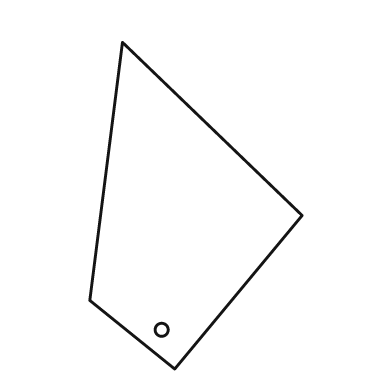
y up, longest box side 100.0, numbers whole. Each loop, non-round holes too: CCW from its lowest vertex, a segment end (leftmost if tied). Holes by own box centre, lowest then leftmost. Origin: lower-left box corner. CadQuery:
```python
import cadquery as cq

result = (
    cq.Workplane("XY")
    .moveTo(26.0, 0.0)
    .lineTo(65.0, 47.0)
    .lineTo(10.0, 100.0)
    .lineTo(0.0, 21.0)
    .close()
    .moveTo(22.0, 12.0)
    .circle(2.0)
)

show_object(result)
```